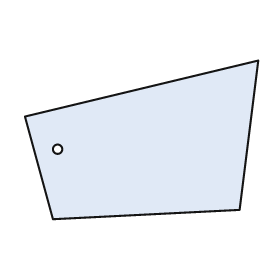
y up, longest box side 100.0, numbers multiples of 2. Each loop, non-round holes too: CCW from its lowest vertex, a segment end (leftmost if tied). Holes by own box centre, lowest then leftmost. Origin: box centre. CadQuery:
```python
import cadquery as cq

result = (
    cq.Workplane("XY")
    .moveTo(-38.0, -34.0)
    .lineTo(42.0, -30.0)
    .lineTo(50.0, 34.0)
    .lineTo(-50.0, 10.0)
    .close()
    .moveTo(-36.0, -4.0)
    .circle(2.0)
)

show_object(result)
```